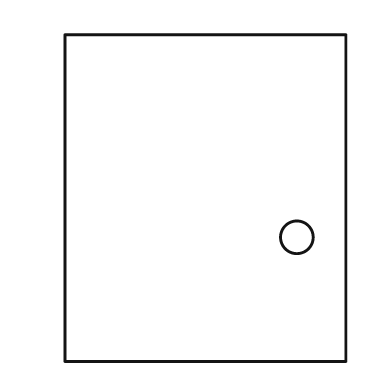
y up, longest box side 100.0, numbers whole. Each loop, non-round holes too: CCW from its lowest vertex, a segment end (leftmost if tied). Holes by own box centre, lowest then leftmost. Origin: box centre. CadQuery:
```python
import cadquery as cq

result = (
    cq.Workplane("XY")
    .moveTo(-43.0, -50.0)
    .lineTo(43.0, -50.0)
    .lineTo(43.0, 50.0)
    .lineTo(-43.0, 50.0)
    .close()
    .moveTo(28.0, -12.0)
    .circle(5.0)
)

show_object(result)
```